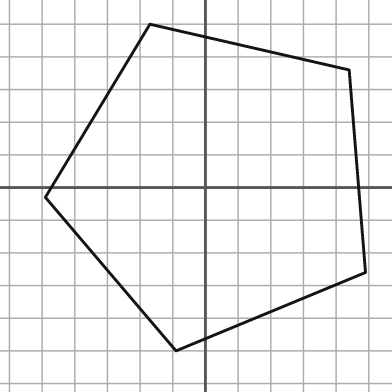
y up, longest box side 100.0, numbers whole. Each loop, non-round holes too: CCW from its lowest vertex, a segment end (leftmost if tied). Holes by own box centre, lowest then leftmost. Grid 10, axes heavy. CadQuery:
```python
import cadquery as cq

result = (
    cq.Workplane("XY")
    .moveTo(-9.0, -50.0)
    .lineTo(49.0, -26.0)
    .lineTo(44.0, 36.0)
    .lineTo(-17.0, 50.0)
    .lineTo(-49.0, -3.0)
    .close()
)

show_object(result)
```